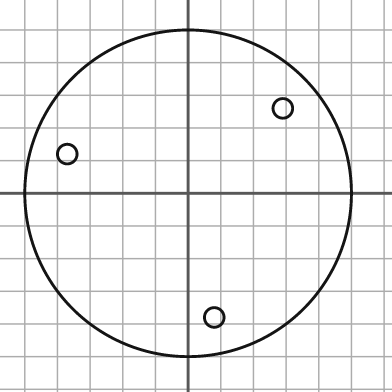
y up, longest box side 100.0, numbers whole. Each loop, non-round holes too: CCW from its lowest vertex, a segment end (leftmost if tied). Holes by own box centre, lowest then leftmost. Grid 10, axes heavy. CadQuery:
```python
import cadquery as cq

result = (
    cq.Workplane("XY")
    .moveTo(0.0, 0.0)
    .circle(50.0)
    .moveTo(8.0, -38.0)
    .circle(3.0)
    .moveTo(-37.0, 12.0)
    .circle(3.0)
    .moveTo(29.0, 26.0)
    .circle(3.0)
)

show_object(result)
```